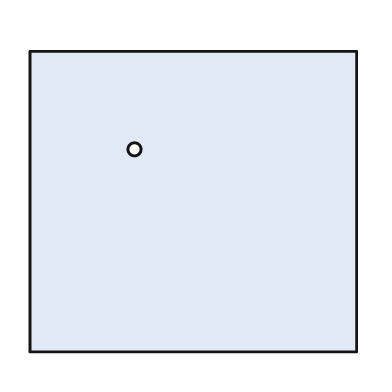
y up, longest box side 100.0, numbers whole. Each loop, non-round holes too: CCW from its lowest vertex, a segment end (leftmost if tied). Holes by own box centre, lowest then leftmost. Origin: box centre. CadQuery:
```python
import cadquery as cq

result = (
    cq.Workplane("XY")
    .moveTo(-50.0, -46.0)
    .lineTo(50.0, -46.0)
    .lineTo(50.0, 46.0)
    .lineTo(-50.0, 46.0)
    .close()
    .moveTo(-18.0, 16.0)
    .circle(2.0)
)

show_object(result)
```